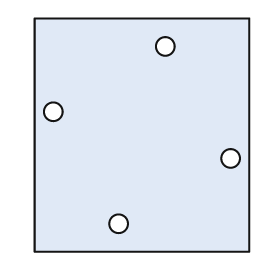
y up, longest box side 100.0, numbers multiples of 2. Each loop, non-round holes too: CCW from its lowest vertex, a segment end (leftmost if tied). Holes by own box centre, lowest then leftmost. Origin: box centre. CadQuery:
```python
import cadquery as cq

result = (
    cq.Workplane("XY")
    .moveTo(-46.0, -50.0)
    .lineTo(46.0, -50.0)
    .lineTo(46.0, 50.0)
    .lineTo(-46.0, 50.0)
    .close()
    .moveTo(-10.0, -38.0)
    .circle(4.0)
    .moveTo(38.0, -10.0)
    .circle(4.0)
    .moveTo(-38.0, 10.0)
    .circle(4.0)
    .moveTo(10.0, 38.0)
    .circle(4.0)
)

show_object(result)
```